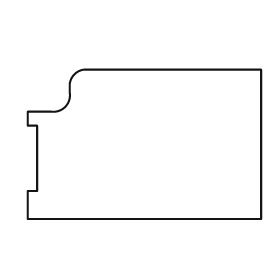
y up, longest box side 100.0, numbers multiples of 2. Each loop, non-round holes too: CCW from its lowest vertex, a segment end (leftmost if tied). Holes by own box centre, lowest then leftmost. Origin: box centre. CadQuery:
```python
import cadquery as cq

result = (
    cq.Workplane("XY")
    .moveTo(-50.0, -32.0)
    .lineTo(50.0, -32.0)
    .lineTo(50.0, 32.0)
    .lineTo(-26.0, 32.0)
    .threePointArc((-30.0, 30.0), (-32.0, 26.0))
    .lineTo(-32.0, 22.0)
    .threePointArc((-34.0, 16.0), (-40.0, 14.0))
    .lineTo(-50.0, 14.0)
    .lineTo(-50.0, 8.0)
    .lineTo(-46.0, 8.0)
    .lineTo(-46.0, -20.0)
    .lineTo(-50.0, -20.0)
    .close()
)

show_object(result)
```